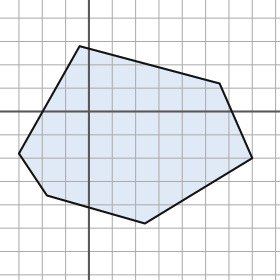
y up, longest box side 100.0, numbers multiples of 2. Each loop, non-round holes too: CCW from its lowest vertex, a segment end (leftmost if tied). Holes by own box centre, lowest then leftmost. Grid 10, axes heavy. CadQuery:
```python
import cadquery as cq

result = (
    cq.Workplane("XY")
    .moveTo(24.0, -48.0)
    .lineTo(70.0, -20.0)
    .lineTo(56.0, 12.0)
    .lineTo(-4.0, 28.0)
    .lineTo(-30.0, -18.0)
    .lineTo(-18.0, -36.0)
    .close()
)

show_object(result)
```